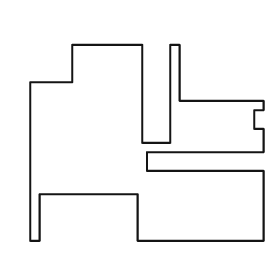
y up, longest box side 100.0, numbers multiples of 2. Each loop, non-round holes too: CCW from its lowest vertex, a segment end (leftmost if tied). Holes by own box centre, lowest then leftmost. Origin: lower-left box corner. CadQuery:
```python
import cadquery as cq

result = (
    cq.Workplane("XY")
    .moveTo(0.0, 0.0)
    .lineTo(4.0, 0.0)
    .lineTo(4.0, 20.0)
    .lineTo(46.0, 20.0)
    .lineTo(46.0, 0.0)
    .lineTo(100.0, 0.0)
    .lineTo(100.0, 30.0)
    .lineTo(50.0, 30.0)
    .lineTo(50.0, 38.0)
    .lineTo(100.0, 38.0)
    .lineTo(100.0, 48.0)
    .lineTo(96.0, 48.0)
    .lineTo(96.0, 56.0)
    .lineTo(100.0, 56.0)
    .lineTo(100.0, 60.0)
    .lineTo(64.0, 60.0)
    .lineTo(64.0, 84.0)
    .lineTo(60.0, 84.0)
    .lineTo(60.0, 42.0)
    .lineTo(48.0, 42.0)
    .lineTo(48.0, 84.0)
    .lineTo(18.0, 84.0)
    .lineTo(18.0, 68.0)
    .lineTo(0.0, 68.0)
    .close()
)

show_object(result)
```